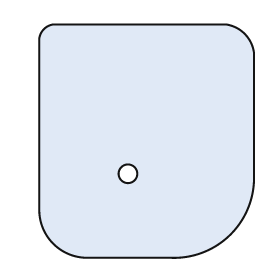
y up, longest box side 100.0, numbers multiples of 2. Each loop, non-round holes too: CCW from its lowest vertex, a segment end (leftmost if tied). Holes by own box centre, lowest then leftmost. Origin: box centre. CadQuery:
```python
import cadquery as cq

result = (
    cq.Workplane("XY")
    .moveTo(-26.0, -50.0)
    .lineTo(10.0, -50.0)
    .threePointArc((36.0, -40.0), (46.0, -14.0))
    .lineTo(46.0, 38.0)
    .threePointArc((42.0, 46.0), (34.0, 50.0))
    .lineTo(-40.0, 50.0)
    .threePointArc((-44.0, 48.0), (-46.0, 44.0))
    .lineTo(-46.0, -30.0)
    .threePointArc((-40.0, -44.0), (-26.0, -50.0))
    .close()
    .moveTo(-8.0, -14.0)
    .circle(4.0)
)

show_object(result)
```